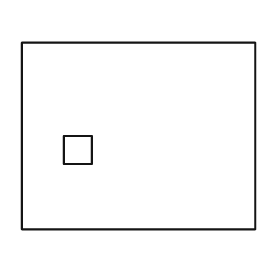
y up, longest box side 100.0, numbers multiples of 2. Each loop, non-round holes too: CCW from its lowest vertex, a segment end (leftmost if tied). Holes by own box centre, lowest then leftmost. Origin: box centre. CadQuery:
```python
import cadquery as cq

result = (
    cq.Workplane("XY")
    .moveTo(-50.0, -40.0)
    .lineTo(50.0, -40.0)
    .lineTo(50.0, 40.0)
    .lineTo(-50.0, 40.0)
    .close()
    .moveTo(-32.0, -12.0)
    .lineTo(-20.0, -12.0)
    .lineTo(-20.0, 0.0)
    .lineTo(-32.0, 0.0)
    .close()
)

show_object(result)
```